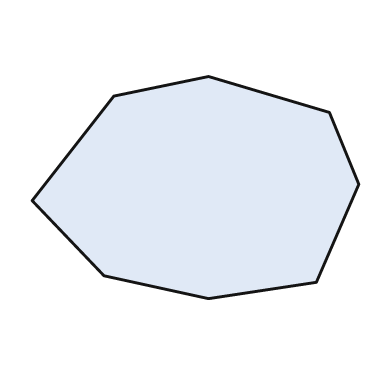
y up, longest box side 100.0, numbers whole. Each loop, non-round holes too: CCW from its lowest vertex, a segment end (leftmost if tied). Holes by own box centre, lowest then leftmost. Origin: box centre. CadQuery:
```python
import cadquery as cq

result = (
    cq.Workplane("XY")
    .moveTo(4.0, -34.0)
    .lineTo(37.0, -29.0)
    .lineTo(50.0, 1.0)
    .lineTo(41.0, 23.0)
    .lineTo(4.0, 34.0)
    .lineTo(-25.0, 28.0)
    .lineTo(-50.0, -4.0)
    .lineTo(-28.0, -27.0)
    .close()
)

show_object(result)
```